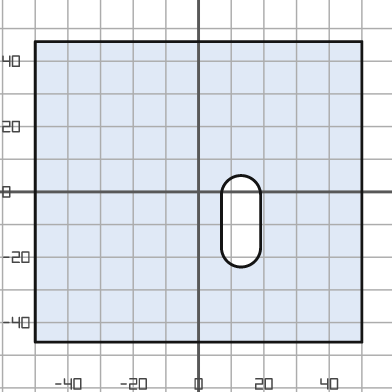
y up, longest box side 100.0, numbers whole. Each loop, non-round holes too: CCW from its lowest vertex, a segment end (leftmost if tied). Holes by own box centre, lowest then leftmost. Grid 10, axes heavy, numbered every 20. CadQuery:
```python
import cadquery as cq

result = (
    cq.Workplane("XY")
    .moveTo(-50.0, -46.0)
    .lineTo(50.0, -46.0)
    .lineTo(50.0, 46.0)
    .lineTo(-50.0, 46.0)
    .close()
    .moveTo(7.0, -17.0)
    .threePointArc((13.0, -23.0), (19.0, -17.0))
    .lineTo(19.0, -1.0)
    .threePointArc((13.0, 5.0), (7.0, -1.0))
    .close()
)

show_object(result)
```